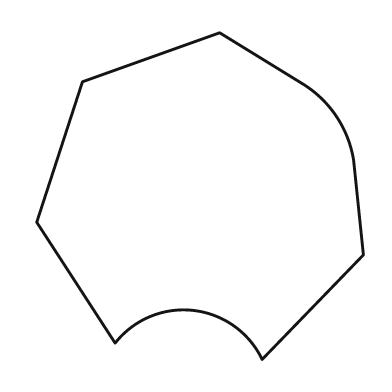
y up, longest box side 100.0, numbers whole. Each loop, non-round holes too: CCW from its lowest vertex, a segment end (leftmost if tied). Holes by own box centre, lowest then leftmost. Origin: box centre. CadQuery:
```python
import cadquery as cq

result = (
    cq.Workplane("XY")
    .moveTo(19.0, -50.0)
    .lineTo(50.0, -18.0)
    .lineTo(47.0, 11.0)
    .threePointArc((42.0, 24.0), (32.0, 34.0))
    .lineTo(6.0, 50.0)
    .lineTo(-36.0, 35.0)
    .lineTo(-50.0, -8.0)
    .lineTo(-26.0, -45.0)
    .threePointArc((-2.0, -35.0), (19.0, -50.0))
    .close()
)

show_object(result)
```